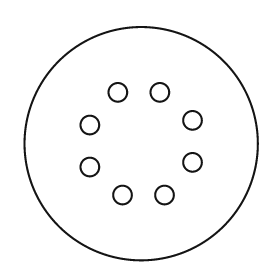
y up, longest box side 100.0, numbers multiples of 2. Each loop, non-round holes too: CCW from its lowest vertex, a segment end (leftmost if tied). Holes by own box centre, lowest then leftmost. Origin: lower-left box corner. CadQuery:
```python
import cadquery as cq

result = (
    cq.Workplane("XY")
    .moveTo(50.0, 50.0)
    .circle(50.0)
    .moveTo(42.0, 28.0)
    .circle(4.0)
    .moveTo(60.0, 28.0)
    .circle(4.0)
    .moveTo(28.0, 40.0)
    .circle(4.0)
    .moveTo(72.0, 42.0)
    .circle(4.0)
    .moveTo(28.0, 58.0)
    .circle(4.0)
    .moveTo(72.0, 60.0)
    .circle(4.0)
    .moveTo(40.0, 72.0)
    .circle(4.0)
    .moveTo(58.0, 72.0)
    .circle(4.0)
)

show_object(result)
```